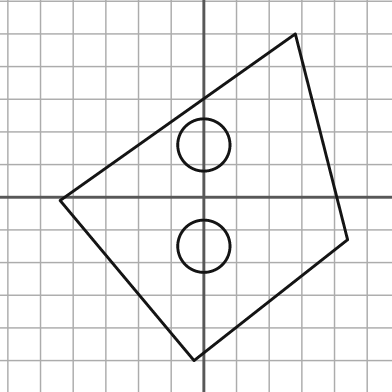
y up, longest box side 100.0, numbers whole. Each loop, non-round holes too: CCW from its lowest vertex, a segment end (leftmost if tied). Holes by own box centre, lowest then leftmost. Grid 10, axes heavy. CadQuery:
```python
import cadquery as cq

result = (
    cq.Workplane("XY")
    .moveTo(-3.0, -50.0)
    .lineTo(44.0, -13.0)
    .lineTo(28.0, 50.0)
    .lineTo(-44.0, -1.0)
    .close()
    .moveTo(0.0, -15.0)
    .circle(8.0)
    .moveTo(0.0, 16.0)
    .circle(8.0)
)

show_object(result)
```